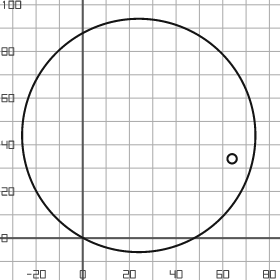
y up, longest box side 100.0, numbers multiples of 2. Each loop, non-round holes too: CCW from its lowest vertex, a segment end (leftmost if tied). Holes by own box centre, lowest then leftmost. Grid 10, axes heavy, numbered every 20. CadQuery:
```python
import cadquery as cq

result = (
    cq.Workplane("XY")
    .moveTo(24.0, 44.0)
    .circle(50.0)
    .moveTo(64.0, 34.0)
    .circle(2.0)
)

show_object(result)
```